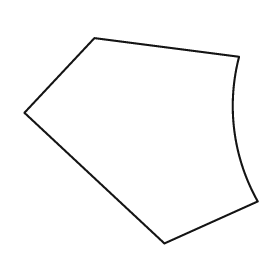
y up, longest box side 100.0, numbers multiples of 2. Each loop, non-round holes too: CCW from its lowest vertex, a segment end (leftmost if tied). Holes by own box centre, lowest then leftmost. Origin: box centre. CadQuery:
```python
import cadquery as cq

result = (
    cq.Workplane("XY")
    .moveTo(10.0, -44.0)
    .lineTo(50.0, -26.0)
    .threePointArc((40.0, 4.0), (42.0, 36.0))
    .lineTo(-20.0, 44.0)
    .lineTo(-50.0, 12.0)
    .close()
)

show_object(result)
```